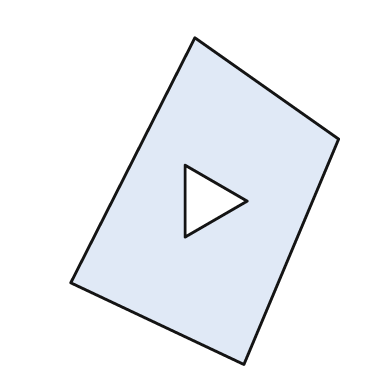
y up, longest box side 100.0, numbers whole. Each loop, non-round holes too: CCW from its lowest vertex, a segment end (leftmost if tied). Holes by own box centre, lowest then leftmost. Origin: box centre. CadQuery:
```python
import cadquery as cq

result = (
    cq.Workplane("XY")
    .moveTo(12.0, -50.0)
    .lineTo(41.0, 19.0)
    .lineTo(-3.0, 50.0)
    .lineTo(-41.0, -25.0)
    .close()
    .moveTo(-6.0, -11.0)
    .lineTo(13.0, 0.0)
    .lineTo(-6.0, 11.0)
    .close()
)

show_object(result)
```